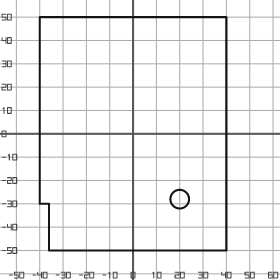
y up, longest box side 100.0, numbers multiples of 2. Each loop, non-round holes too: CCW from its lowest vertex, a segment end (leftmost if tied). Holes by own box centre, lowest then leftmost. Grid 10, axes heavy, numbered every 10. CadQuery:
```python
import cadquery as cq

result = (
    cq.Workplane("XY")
    .moveTo(-36.0, -50.0)
    .lineTo(40.0, -50.0)
    .lineTo(40.0, 50.0)
    .lineTo(-40.0, 50.0)
    .lineTo(-40.0, -30.0)
    .lineTo(-36.0, -30.0)
    .close()
    .moveTo(20.0, -28.0)
    .circle(4.0)
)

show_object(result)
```